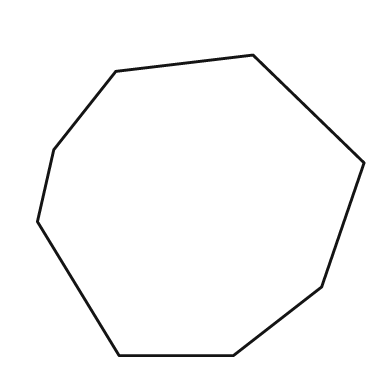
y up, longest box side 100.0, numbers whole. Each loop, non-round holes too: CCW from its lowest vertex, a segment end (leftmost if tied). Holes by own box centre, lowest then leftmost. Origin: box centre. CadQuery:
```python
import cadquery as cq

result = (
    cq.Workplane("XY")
    .moveTo(-25.0, -46.0)
    .lineTo(10.0, -46.0)
    .lineTo(37.0, -25.0)
    .lineTo(50.0, 13.0)
    .lineTo(16.0, 46.0)
    .lineTo(-26.0, 41.0)
    .lineTo(-45.0, 17.0)
    .lineTo(-50.0, -5.0)
    .close()
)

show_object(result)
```